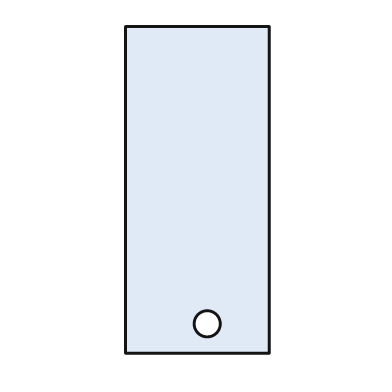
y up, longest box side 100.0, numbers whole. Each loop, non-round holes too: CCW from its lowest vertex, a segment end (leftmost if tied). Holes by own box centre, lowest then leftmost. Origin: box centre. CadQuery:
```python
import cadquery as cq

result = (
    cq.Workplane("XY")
    .moveTo(-22.0, -50.0)
    .lineTo(22.0, -50.0)
    .lineTo(22.0, 50.0)
    .lineTo(-22.0, 50.0)
    .close()
    .moveTo(3.0, -41.0)
    .circle(4.0)
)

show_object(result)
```